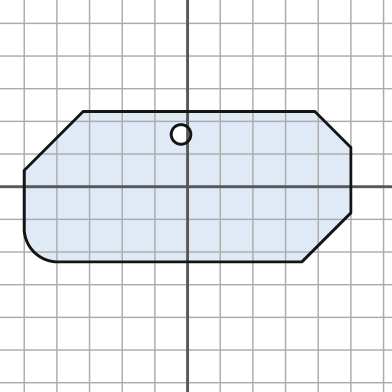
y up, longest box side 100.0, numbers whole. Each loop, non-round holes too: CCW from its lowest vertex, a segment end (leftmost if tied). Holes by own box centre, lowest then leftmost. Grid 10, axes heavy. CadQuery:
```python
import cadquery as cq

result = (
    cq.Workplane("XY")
    .moveTo(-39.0, -23.0)
    .lineTo(35.0, -23.0)
    .lineTo(50.0, -8.0)
    .lineTo(50.0, 12.0)
    .lineTo(39.0, 23.0)
    .lineTo(-32.0, 23.0)
    .lineTo(-50.0, 5.0)
    .lineTo(-50.0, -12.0)
    .threePointArc((-47.0, -20.0), (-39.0, -23.0))
    .close()
    .moveTo(-2.0, 16.0)
    .circle(3.0)
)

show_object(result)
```